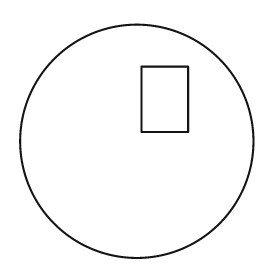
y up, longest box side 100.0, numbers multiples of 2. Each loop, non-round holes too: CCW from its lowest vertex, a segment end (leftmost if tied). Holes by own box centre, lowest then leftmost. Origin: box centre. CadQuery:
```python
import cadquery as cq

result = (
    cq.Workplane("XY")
    .moveTo(0.0, 0.0)
    .circle(50.0)
    .moveTo(2.0, 4.0)
    .lineTo(22.0, 4.0)
    .lineTo(22.0, 32.0)
    .lineTo(2.0, 32.0)
    .close()
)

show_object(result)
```